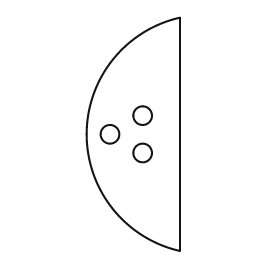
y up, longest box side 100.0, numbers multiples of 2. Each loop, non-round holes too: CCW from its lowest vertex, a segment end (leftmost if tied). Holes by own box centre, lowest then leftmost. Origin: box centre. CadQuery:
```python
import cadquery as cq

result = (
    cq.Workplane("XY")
    .moveTo(20.0, -50.0)
    .lineTo(20.0, 50.0)
    .threePointArc((-20.0, 0.0), (20.0, -50.0))
    .close()
    .moveTo(4.0, -8.0)
    .circle(4.0)
    .moveTo(-10.0, 0.0)
    .circle(4.0)
    .moveTo(4.0, 8.0)
    .circle(4.0)
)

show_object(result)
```